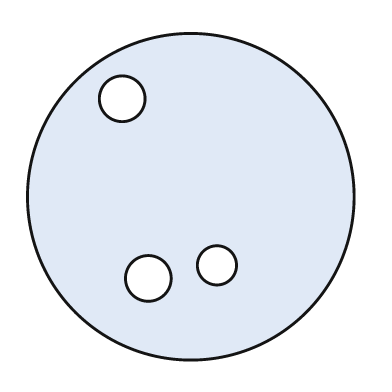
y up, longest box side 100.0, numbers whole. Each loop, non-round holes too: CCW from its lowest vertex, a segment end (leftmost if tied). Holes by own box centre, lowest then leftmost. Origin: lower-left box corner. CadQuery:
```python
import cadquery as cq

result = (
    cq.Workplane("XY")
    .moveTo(50.0, 50.0)
    .circle(50.0)
    .moveTo(37.0, 25.0)
    .circle(7.0)
    .moveTo(58.0, 29.0)
    .circle(6.0)
    .moveTo(29.0, 80.0)
    .circle(7.0)
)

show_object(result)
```